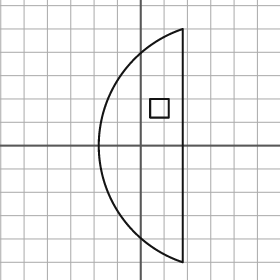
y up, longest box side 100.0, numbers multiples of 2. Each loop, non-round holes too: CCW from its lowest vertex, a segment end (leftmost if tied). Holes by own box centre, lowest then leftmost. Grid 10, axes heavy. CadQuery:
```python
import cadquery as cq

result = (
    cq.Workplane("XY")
    .moveTo(18.0, -50.0)
    .lineTo(18.0, 50.0)
    .threePointArc((-18.0, 0.0), (18.0, -50.0))
    .close()
    .moveTo(4.0, 12.0)
    .lineTo(12.0, 12.0)
    .lineTo(12.0, 20.0)
    .lineTo(4.0, 20.0)
    .close()
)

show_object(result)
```